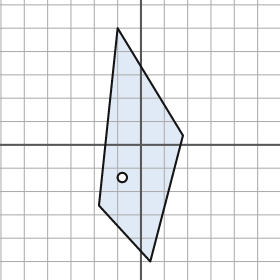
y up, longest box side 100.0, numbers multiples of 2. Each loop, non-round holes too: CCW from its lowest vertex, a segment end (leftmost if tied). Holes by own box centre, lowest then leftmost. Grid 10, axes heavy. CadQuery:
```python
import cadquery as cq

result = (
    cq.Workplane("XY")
    .moveTo(4.0, -50.0)
    .lineTo(18.0, 4.0)
    .lineTo(-10.0, 50.0)
    .lineTo(-18.0, -26.0)
    .close()
    .moveTo(-8.0, -14.0)
    .circle(2.0)
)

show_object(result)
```